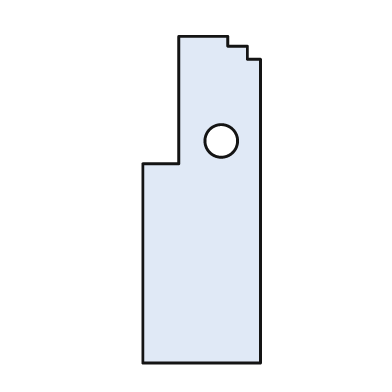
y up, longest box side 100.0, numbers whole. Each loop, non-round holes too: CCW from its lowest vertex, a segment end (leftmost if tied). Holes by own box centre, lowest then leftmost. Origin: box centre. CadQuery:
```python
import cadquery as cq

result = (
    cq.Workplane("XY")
    .moveTo(-18.0, -50.0)
    .lineTo(18.0, -50.0)
    .lineTo(18.0, 43.0)
    .lineTo(14.0, 43.0)
    .lineTo(14.0, 47.0)
    .lineTo(8.0, 47.0)
    .lineTo(8.0, 50.0)
    .lineTo(-7.0, 50.0)
    .lineTo(-7.0, 11.0)
    .lineTo(-18.0, 11.0)
    .close()
    .moveTo(6.0, 18.0)
    .circle(5.0)
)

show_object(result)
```